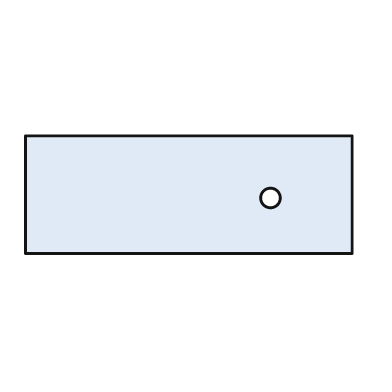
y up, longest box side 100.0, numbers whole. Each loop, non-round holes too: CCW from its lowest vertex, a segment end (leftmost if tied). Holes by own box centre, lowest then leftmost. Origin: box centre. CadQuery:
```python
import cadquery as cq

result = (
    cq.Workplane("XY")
    .moveTo(-50.0, -18.0)
    .lineTo(50.0, -18.0)
    .lineTo(50.0, 18.0)
    .lineTo(-50.0, 18.0)
    .close()
    .moveTo(25.0, -1.0)
    .circle(3.0)
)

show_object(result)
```